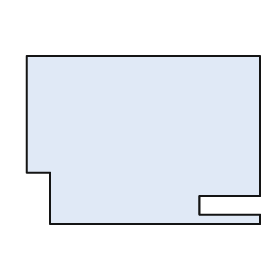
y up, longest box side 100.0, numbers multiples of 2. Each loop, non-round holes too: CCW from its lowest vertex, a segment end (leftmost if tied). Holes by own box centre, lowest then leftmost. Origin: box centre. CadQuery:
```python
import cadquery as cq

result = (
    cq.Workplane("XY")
    .moveTo(-40.0, -36.0)
    .lineTo(50.0, -36.0)
    .lineTo(50.0, -32.0)
    .lineTo(24.0, -32.0)
    .lineTo(24.0, -24.0)
    .lineTo(50.0, -24.0)
    .lineTo(50.0, 36.0)
    .lineTo(-50.0, 36.0)
    .lineTo(-50.0, -14.0)
    .lineTo(-40.0, -14.0)
    .close()
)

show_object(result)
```